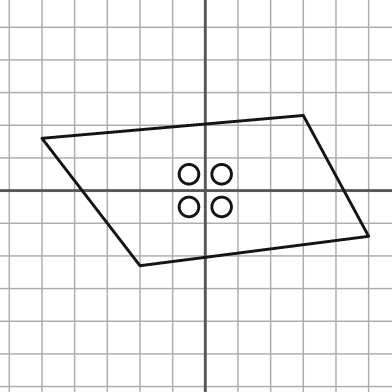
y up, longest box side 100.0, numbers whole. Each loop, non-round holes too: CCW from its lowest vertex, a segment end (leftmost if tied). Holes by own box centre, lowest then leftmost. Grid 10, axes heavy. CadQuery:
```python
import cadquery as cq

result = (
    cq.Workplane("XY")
    .moveTo(-20.0, -23.0)
    .lineTo(50.0, -14.0)
    .lineTo(30.0, 23.0)
    .lineTo(-50.0, 16.0)
    .close()
    .moveTo(-5.0, -5.0)
    .circle(3.0)
    .moveTo(5.0, -5.0)
    .circle(3.0)
    .moveTo(-5.0, 5.0)
    .circle(3.0)
    .moveTo(5.0, 5.0)
    .circle(3.0)
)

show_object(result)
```